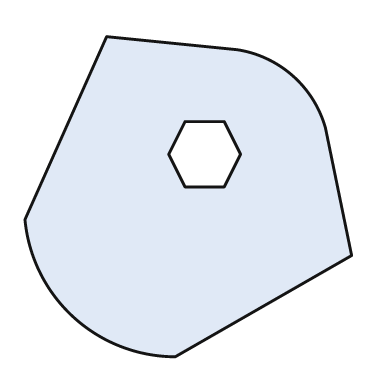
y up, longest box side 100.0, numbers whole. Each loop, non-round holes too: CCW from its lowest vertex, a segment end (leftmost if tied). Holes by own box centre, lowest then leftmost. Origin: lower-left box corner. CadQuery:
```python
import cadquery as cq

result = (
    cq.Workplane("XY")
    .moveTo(46.0, 0.0)
    .lineTo(100.0, 31.0)
    .lineTo(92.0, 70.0)
    .threePointArc((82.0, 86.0), (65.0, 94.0))
    .lineTo(25.0, 98.0)
    .lineTo(0.0, 42.0)
    .threePointArc((15.0, 12.0), (46.0, 0.0))
    .close()
    .moveTo(49.0, 52.0)
    .lineTo(61.0, 52.0)
    .lineTo(66.0, 62.0)
    .lineTo(61.0, 72.0)
    .lineTo(49.0, 72.0)
    .lineTo(44.0, 62.0)
    .close()
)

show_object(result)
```